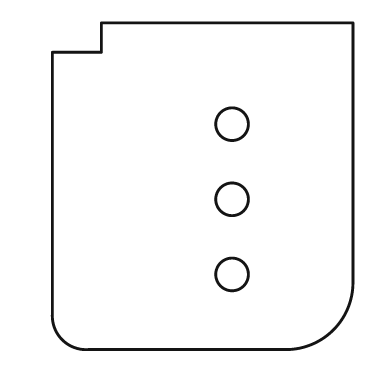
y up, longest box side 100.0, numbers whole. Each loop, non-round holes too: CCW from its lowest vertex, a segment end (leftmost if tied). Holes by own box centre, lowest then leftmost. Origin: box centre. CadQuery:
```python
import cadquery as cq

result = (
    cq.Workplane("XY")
    .moveTo(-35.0, -50.0)
    .lineTo(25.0, -50.0)
    .threePointArc((40.0, -44.0), (46.0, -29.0))
    .lineTo(46.0, 50.0)
    .lineTo(-31.0, 50.0)
    .lineTo(-31.0, 41.0)
    .lineTo(-46.0, 41.0)
    .lineTo(-46.0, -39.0)
    .threePointArc((-43.0, -47.0), (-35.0, -50.0))
    .close()
    .moveTo(9.0, -27.0)
    .circle(5.0)
    .moveTo(9.0, -4.0)
    .circle(5.0)
    .moveTo(9.0, 19.0)
    .circle(5.0)
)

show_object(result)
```